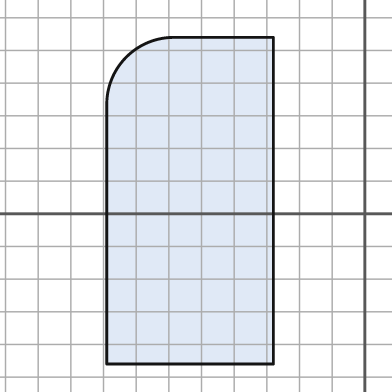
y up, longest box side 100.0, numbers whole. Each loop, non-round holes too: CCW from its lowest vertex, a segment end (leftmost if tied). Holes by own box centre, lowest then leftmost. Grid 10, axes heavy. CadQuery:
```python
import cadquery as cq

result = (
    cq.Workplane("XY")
    .moveTo(-79.0, -46.0)
    .lineTo(-28.0, -46.0)
    .lineTo(-28.0, 54.0)
    .lineTo(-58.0, 54.0)
    .threePointArc((-73.0, 48.0), (-79.0, 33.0))
    .close()
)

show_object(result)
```